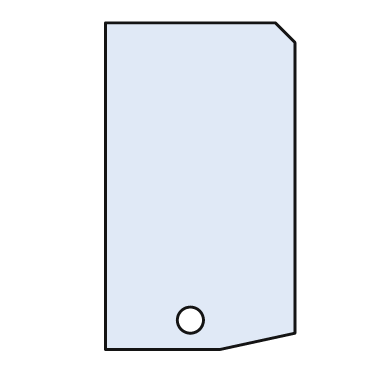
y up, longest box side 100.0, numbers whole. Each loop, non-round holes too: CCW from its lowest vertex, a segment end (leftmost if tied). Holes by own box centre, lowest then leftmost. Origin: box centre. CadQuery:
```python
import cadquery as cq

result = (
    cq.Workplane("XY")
    .moveTo(-29.0, -50.0)
    .lineTo(6.0, -50.0)
    .lineTo(29.0, -45.0)
    .lineTo(29.0, 44.0)
    .lineTo(23.0, 50.0)
    .lineTo(-29.0, 50.0)
    .close()
    .moveTo(-3.0, -41.0)
    .circle(4.0)
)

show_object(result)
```